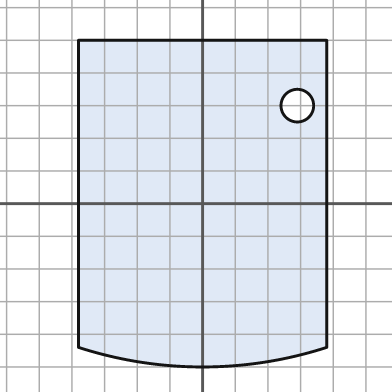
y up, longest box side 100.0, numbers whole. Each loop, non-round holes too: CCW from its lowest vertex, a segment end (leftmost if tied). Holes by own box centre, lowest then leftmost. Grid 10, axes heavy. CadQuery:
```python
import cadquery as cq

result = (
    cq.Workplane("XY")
    .moveTo(-38.0, -44.0)
    .threePointArc((0.0, -50.0), (38.0, -44.0))
    .lineTo(38.0, 50.0)
    .lineTo(-38.0, 50.0)
    .close()
    .moveTo(29.0, 30.0)
    .circle(5.0)
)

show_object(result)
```